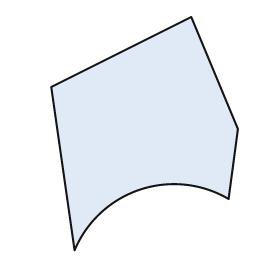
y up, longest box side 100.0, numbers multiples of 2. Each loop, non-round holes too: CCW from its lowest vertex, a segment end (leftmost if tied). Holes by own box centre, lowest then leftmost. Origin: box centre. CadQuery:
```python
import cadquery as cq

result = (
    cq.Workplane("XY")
    .moveTo(-30.0, -50.0)
    .threePointArc((-2.0, -24.0), (36.0, -28.0))
    .lineTo(40.0, 2.0)
    .lineTo(20.0, 50.0)
    .lineTo(-40.0, 20.0)
    .close()
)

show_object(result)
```